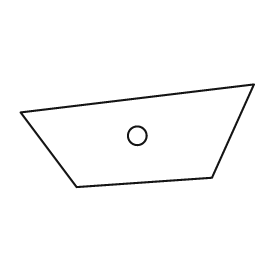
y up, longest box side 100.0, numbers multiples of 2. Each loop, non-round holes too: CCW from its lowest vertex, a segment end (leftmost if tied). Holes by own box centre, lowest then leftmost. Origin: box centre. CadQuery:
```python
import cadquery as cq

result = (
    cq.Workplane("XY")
    .moveTo(-26.0, -22.0)
    .lineTo(32.0, -18.0)
    .lineTo(50.0, 22.0)
    .lineTo(-50.0, 10.0)
    .close()
    .moveTo(0.0, 0.0)
    .circle(4.0)
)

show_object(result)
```